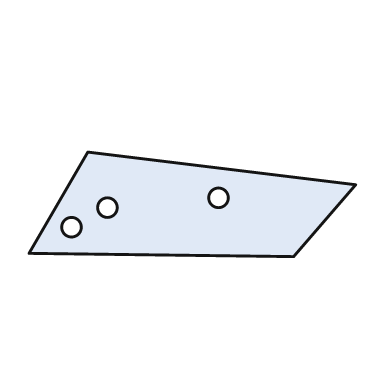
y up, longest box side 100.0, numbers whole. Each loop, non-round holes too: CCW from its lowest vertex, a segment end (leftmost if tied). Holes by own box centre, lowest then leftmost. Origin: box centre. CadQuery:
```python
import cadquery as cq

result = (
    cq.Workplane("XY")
    .moveTo(31.0, -16.0)
    .lineTo(50.0, 6.0)
    .lineTo(-32.0, 16.0)
    .lineTo(-50.0, -15.0)
    .close()
    .moveTo(-37.0, -7.0)
    .circle(3.0)
    .moveTo(-26.0, -1.0)
    .circle(3.0)
    .moveTo(8.0, 2.0)
    .circle(3.0)
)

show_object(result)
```